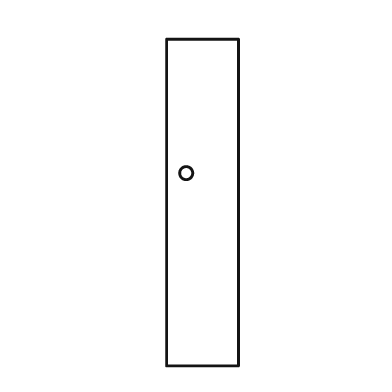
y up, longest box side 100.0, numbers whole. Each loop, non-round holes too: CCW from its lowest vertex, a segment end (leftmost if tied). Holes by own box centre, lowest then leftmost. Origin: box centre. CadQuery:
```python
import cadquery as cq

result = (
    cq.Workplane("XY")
    .moveTo(-11.0, -50.0)
    .lineTo(11.0, -50.0)
    .lineTo(11.0, 50.0)
    .lineTo(-11.0, 50.0)
    .close()
    .moveTo(-5.0, 9.0)
    .circle(2.0)
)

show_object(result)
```